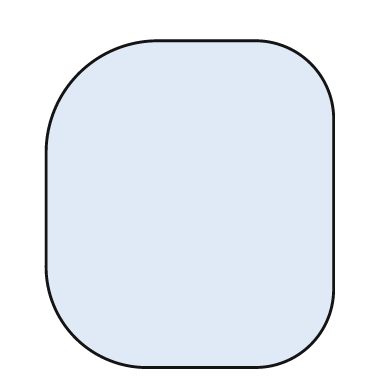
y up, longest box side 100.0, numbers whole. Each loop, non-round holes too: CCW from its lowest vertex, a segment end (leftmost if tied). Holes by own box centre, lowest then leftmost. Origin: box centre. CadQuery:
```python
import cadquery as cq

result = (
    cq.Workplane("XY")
    .moveTo(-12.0, -50.0)
    .lineTo(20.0, -50.0)
    .threePointArc((37.0, -43.0), (44.0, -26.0))
    .lineTo(44.0, 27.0)
    .threePointArc((37.0, 43.0), (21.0, 50.0))
    .lineTo(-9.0, 50.0)
    .threePointArc((-34.0, 40.0), (-44.0, 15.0))
    .lineTo(-44.0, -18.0)
    .threePointArc((-35.0, -41.0), (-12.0, -50.0))
    .close()
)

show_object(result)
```